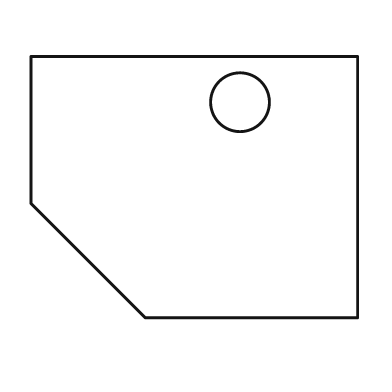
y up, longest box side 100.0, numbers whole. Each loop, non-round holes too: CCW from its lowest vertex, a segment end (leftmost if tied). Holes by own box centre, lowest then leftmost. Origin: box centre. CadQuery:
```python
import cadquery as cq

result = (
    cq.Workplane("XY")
    .moveTo(-15.0, -40.0)
    .lineTo(50.0, -40.0)
    .lineTo(50.0, 40.0)
    .lineTo(-50.0, 40.0)
    .lineTo(-50.0, -5.0)
    .close()
    .moveTo(14.0, 26.0)
    .circle(9.0)
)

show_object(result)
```